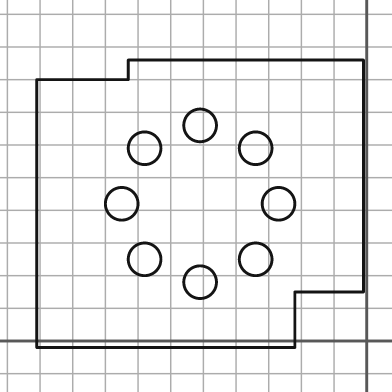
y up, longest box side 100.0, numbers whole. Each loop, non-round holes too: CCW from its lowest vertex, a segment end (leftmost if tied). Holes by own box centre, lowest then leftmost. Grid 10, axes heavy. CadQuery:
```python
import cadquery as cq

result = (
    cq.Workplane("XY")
    .moveTo(-101.0, -2.0)
    .lineTo(-22.0, -2.0)
    .lineTo(-22.0, 15.0)
    .lineTo(-1.0, 15.0)
    .lineTo(-1.0, 86.0)
    .lineTo(-73.0, 86.0)
    .lineTo(-73.0, 80.0)
    .lineTo(-101.0, 80.0)
    .close()
    .moveTo(-51.0, 18.0)
    .circle(5.0)
    .moveTo(-68.0, 25.0)
    .circle(5.0)
    .moveTo(-34.0, 25.0)
    .circle(5.0)
    .moveTo(-75.0, 42.0)
    .circle(5.0)
    .moveTo(-27.0, 42.0)
    .circle(5.0)
    .moveTo(-68.0, 59.0)
    .circle(5.0)
    .moveTo(-34.0, 59.0)
    .circle(5.0)
    .moveTo(-51.0, 66.0)
    .circle(5.0)
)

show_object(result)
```